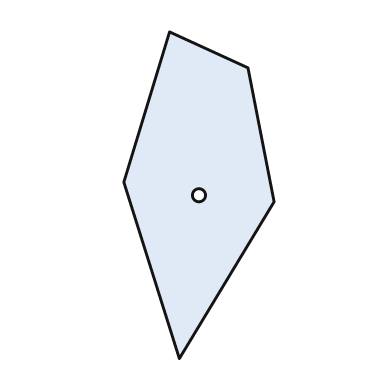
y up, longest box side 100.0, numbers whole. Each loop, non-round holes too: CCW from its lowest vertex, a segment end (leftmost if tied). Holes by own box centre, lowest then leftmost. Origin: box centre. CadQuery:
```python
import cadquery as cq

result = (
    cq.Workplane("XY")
    .moveTo(-6.0, -50.0)
    .lineTo(23.0, -2.0)
    .lineTo(15.0, 39.0)
    .lineTo(-9.0, 50.0)
    .lineTo(-23.0, 4.0)
    .close()
    .moveTo(0.0, 0.0)
    .circle(2.0)
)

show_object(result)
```